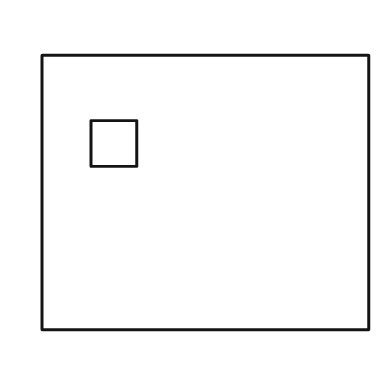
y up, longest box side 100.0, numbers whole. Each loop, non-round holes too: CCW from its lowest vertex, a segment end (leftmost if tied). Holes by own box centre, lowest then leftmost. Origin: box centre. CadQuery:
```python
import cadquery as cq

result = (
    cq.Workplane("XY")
    .moveTo(-50.0, -42.0)
    .lineTo(50.0, -42.0)
    .lineTo(50.0, 42.0)
    .lineTo(-50.0, 42.0)
    .close()
    .moveTo(-35.0, 8.0)
    .lineTo(-21.0, 8.0)
    .lineTo(-21.0, 22.0)
    .lineTo(-35.0, 22.0)
    .close()
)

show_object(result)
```